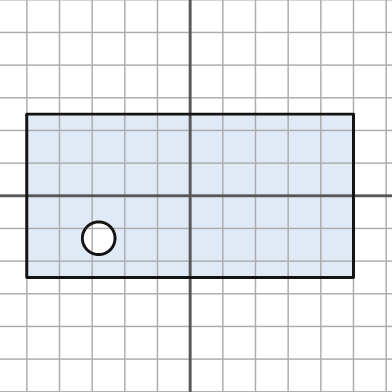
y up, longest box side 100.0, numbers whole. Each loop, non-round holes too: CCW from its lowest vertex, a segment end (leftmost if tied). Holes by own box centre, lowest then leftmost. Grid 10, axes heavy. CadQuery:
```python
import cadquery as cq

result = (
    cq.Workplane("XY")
    .moveTo(-50.0, -25.0)
    .lineTo(50.0, -25.0)
    .lineTo(50.0, 25.0)
    .lineTo(-50.0, 25.0)
    .close()
    .moveTo(-28.0, -13.0)
    .circle(5.0)
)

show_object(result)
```